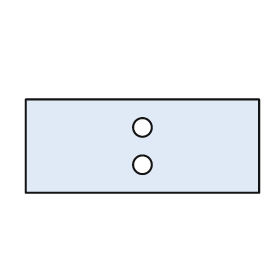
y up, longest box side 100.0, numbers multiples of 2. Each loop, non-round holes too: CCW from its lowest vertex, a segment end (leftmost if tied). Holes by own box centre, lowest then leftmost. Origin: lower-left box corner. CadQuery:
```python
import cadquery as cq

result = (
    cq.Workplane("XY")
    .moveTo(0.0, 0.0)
    .lineTo(100.0, 0.0)
    .lineTo(100.0, 40.0)
    .lineTo(0.0, 40.0)
    .close()
    .moveTo(50.0, 12.0)
    .circle(4.0)
    .moveTo(50.0, 28.0)
    .circle(4.0)
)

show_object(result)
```